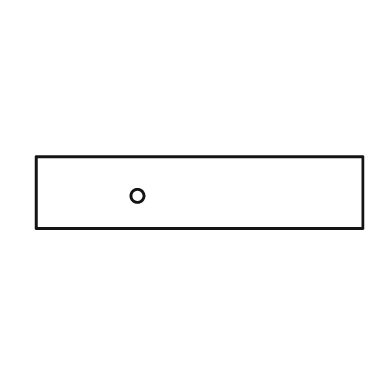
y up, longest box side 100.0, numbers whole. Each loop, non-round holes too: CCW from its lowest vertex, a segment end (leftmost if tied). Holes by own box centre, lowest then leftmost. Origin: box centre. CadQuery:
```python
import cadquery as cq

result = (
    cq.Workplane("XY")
    .moveTo(-50.0, -11.0)
    .lineTo(50.0, -11.0)
    .lineTo(50.0, 11.0)
    .lineTo(-50.0, 11.0)
    .close()
    .moveTo(-19.0, -1.0)
    .circle(2.0)
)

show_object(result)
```